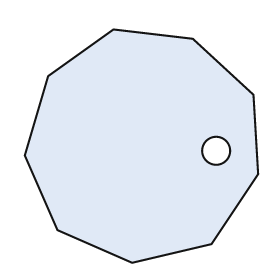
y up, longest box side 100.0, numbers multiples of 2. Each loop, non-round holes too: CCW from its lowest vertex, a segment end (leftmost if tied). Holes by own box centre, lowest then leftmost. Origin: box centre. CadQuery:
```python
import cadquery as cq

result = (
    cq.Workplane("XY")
    .moveTo(-4.0, -50.0)
    .lineTo(30.0, -42.0)
    .lineTo(50.0, -12.0)
    .lineTo(48.0, 22.0)
    .lineTo(22.0, 46.0)
    .lineTo(-12.0, 50.0)
    .lineTo(-40.0, 30.0)
    .lineTo(-50.0, -4.0)
    .lineTo(-36.0, -36.0)
    .close()
    .moveTo(32.0, -2.0)
    .circle(6.0)
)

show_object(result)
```